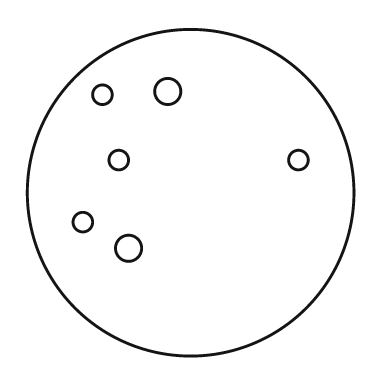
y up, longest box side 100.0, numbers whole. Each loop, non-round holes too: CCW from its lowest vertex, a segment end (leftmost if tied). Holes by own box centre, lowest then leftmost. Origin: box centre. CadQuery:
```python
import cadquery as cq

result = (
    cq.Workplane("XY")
    .moveTo(0.0, 0.0)
    .circle(50.0)
    .moveTo(-19.0, -17.0)
    .circle(4.0)
    .moveTo(-33.0, -9.0)
    .circle(3.0)
    .moveTo(-22.0, 10.0)
    .circle(3.0)
    .moveTo(33.0, 10.0)
    .circle(3.0)
    .moveTo(-27.0, 30.0)
    .circle(3.0)
    .moveTo(-7.0, 31.0)
    .circle(4.0)
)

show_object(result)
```